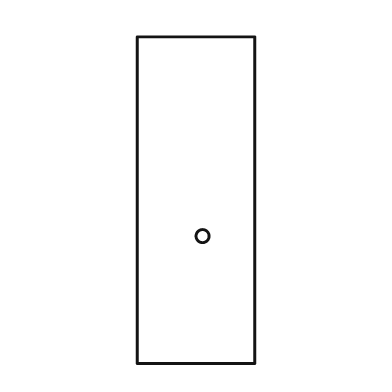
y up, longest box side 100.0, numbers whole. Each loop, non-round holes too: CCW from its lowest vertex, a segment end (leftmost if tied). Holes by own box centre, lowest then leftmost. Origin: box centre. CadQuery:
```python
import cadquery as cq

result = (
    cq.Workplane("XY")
    .moveTo(-18.0, -50.0)
    .lineTo(18.0, -50.0)
    .lineTo(18.0, 50.0)
    .lineTo(-18.0, 50.0)
    .close()
    .moveTo(2.0, -11.0)
    .circle(2.0)
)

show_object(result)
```